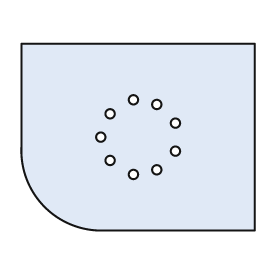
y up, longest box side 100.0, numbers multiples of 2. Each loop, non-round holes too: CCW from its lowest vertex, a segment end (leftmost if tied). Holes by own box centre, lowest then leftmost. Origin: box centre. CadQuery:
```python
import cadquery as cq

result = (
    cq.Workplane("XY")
    .moveTo(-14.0, -40.0)
    .lineTo(50.0, -40.0)
    .lineTo(50.0, 40.0)
    .lineTo(-50.0, 40.0)
    .lineTo(-50.0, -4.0)
    .threePointArc((-40.0, -30.0), (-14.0, -40.0))
    .close()
    .moveTo(-2.0, -16.0)
    .circle(2.0)
    .moveTo(8.0, -14.0)
    .circle(2.0)
    .moveTo(-12.0, -10.0)
    .circle(2.0)
    .moveTo(16.0, -6.0)
    .circle(2.0)
    .moveTo(-16.0, 0.0)
    .circle(2.0)
    .moveTo(16.0, 6.0)
    .circle(2.0)
    .moveTo(-12.0, 10.0)
    .circle(2.0)
    .moveTo(8.0, 14.0)
    .circle(2.0)
    .moveTo(-2.0, 16.0)
    .circle(2.0)
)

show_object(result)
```